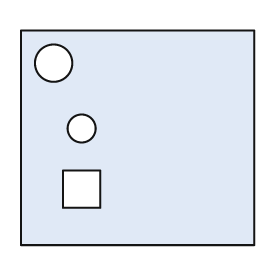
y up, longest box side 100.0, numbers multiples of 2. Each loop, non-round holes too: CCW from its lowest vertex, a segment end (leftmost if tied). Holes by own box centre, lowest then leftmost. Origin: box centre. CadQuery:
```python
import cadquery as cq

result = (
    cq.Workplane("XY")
    .moveTo(-50.0, -46.0)
    .lineTo(50.0, -46.0)
    .lineTo(50.0, 46.0)
    .lineTo(-50.0, 46.0)
    .close()
    .moveTo(-32.0, -30.0)
    .lineTo(-16.0, -30.0)
    .lineTo(-16.0, -14.0)
    .lineTo(-32.0, -14.0)
    .close()
    .moveTo(-24.0, 4.0)
    .circle(6.0)
    .moveTo(-36.0, 32.0)
    .circle(8.0)
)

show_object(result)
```